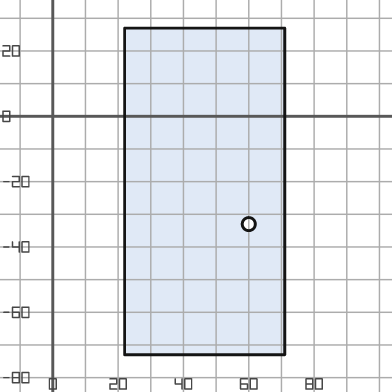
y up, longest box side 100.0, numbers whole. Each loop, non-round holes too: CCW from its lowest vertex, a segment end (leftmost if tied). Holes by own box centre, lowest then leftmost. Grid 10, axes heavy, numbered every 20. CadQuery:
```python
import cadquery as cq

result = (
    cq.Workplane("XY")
    .moveTo(22.0, -73.0)
    .lineTo(71.0, -73.0)
    .lineTo(71.0, 27.0)
    .lineTo(22.0, 27.0)
    .close()
    .moveTo(60.0, -33.0)
    .circle(2.0)
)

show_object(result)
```